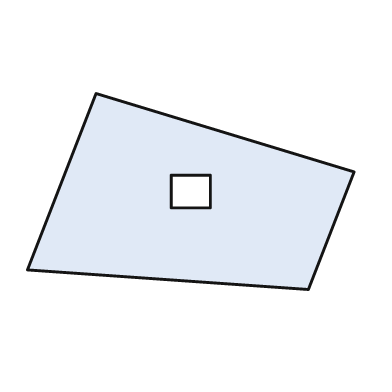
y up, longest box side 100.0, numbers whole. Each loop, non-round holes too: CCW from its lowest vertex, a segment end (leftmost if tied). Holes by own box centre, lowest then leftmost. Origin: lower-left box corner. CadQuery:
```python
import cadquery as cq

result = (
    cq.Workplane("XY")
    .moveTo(86.0, 0.0)
    .lineTo(100.0, 36.0)
    .lineTo(21.0, 60.0)
    .lineTo(0.0, 6.0)
    .close()
    .moveTo(44.0, 25.0)
    .lineTo(56.0, 25.0)
    .lineTo(56.0, 35.0)
    .lineTo(44.0, 35.0)
    .close()
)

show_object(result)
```